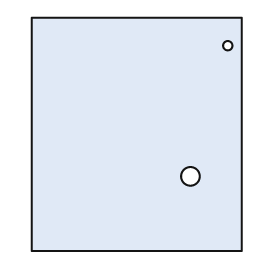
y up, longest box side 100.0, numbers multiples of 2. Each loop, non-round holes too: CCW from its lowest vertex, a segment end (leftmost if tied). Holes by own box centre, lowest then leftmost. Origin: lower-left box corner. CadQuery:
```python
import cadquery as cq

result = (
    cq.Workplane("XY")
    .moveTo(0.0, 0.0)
    .lineTo(90.0, 0.0)
    .lineTo(90.0, 100.0)
    .lineTo(0.0, 100.0)
    .close()
    .moveTo(68.0, 32.0)
    .circle(4.0)
    .moveTo(84.0, 88.0)
    .circle(2.0)
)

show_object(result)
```